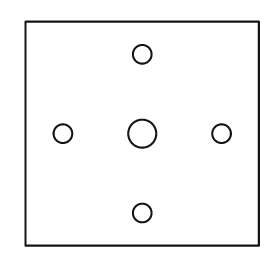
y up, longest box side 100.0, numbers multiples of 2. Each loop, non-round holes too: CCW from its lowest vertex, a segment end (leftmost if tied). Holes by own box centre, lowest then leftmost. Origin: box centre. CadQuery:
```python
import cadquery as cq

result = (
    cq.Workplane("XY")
    .moveTo(-50.0, -48.0)
    .lineTo(50.0, -48.0)
    .lineTo(50.0, 48.0)
    .lineTo(-50.0, 48.0)
    .close()
    .moveTo(0.0, -34.0)
    .circle(4.0)
    .moveTo(-34.0, 0.0)
    .circle(4.0)
    .moveTo(0.0, 0.0)
    .circle(6.0)
    .moveTo(34.0, 0.0)
    .circle(4.0)
    .moveTo(0.0, 34.0)
    .circle(4.0)
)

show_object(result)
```